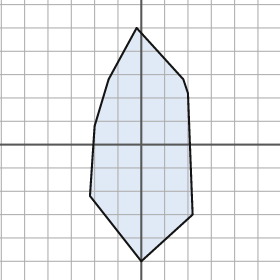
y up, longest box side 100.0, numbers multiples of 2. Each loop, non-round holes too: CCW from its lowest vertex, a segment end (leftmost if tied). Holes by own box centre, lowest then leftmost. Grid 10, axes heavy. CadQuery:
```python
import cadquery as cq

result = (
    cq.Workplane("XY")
    .moveTo(0.0, -50.0)
    .lineTo(22.0, -30.0)
    .lineTo(20.0, 22.0)
    .lineTo(18.0, 28.0)
    .lineTo(-2.0, 50.0)
    .lineTo(-14.0, 28.0)
    .lineTo(-20.0, 8.0)
    .lineTo(-22.0, -22.0)
    .close()
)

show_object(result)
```